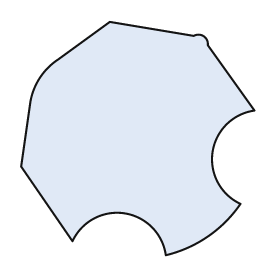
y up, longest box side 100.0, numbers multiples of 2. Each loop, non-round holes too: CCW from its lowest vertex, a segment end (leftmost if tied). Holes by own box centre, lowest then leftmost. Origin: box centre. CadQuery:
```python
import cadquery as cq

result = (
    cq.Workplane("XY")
    .moveTo(12.0, -50.0)
    .threePointArc((30.0, -42.0), (44.0, -28.0))
    .threePointArc((32.0, -6.0), (50.0, 12.0))
    .lineTo(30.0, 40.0)
    .threePointArc((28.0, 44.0), (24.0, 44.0))
    .lineTo(-12.0, 50.0)
    .lineTo(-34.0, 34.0)
    .threePointArc((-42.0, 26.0), (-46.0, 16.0))
    .lineTo(-50.0, -12.0)
    .lineTo(-28.0, -44.0)
    .threePointArc((-6.0, -32.0), (12.0, -50.0))
    .close()
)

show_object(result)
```